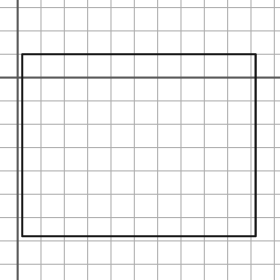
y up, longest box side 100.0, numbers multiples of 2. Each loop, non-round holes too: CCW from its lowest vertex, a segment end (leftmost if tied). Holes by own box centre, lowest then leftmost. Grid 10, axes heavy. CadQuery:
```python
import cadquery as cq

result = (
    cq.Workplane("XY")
    .moveTo(2.0, -68.0)
    .lineTo(102.0, -68.0)
    .lineTo(102.0, 10.0)
    .lineTo(2.0, 10.0)
    .close()
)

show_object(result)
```